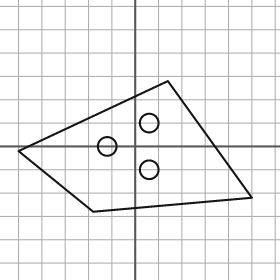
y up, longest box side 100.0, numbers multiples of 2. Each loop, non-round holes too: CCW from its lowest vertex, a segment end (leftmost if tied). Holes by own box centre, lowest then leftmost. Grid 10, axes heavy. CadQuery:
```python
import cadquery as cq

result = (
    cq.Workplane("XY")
    .moveTo(-18.0, -28.0)
    .lineTo(50.0, -22.0)
    .lineTo(14.0, 28.0)
    .lineTo(-50.0, -2.0)
    .close()
    .moveTo(6.0, -10.0)
    .circle(4.0)
    .moveTo(-12.0, 0.0)
    .circle(4.0)
    .moveTo(6.0, 10.0)
    .circle(4.0)
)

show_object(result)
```